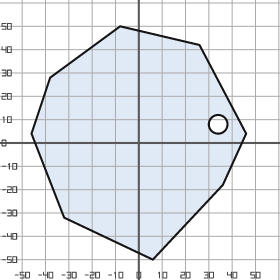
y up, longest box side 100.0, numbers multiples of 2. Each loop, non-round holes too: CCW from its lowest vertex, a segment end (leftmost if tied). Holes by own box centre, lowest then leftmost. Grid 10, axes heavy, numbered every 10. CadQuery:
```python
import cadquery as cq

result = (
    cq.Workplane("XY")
    .moveTo(6.0, -50.0)
    .lineTo(36.0, -18.0)
    .lineTo(46.0, 4.0)
    .lineTo(26.0, 42.0)
    .lineTo(-8.0, 50.0)
    .lineTo(-38.0, 28.0)
    .lineTo(-46.0, 4.0)
    .lineTo(-32.0, -32.0)
    .close()
    .moveTo(34.0, 8.0)
    .circle(4.0)
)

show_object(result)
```